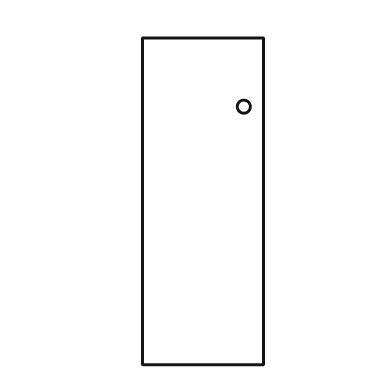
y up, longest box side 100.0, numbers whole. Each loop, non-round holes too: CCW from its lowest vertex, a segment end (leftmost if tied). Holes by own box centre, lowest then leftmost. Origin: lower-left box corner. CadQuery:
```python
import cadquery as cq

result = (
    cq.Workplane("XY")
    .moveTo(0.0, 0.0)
    .lineTo(37.0, 0.0)
    .lineTo(37.0, 100.0)
    .lineTo(0.0, 100.0)
    .close()
    .moveTo(31.0, 79.0)
    .circle(2.0)
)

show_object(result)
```